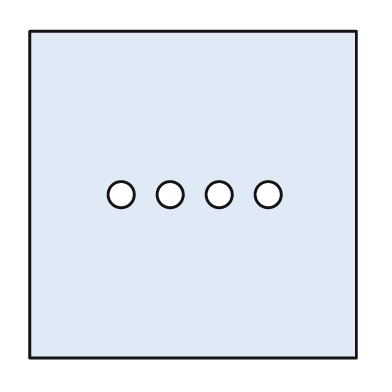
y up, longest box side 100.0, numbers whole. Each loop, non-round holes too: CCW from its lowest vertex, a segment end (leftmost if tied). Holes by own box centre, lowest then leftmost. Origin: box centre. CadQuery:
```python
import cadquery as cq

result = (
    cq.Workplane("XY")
    .moveTo(-50.0, -50.0)
    .lineTo(50.0, -50.0)
    .lineTo(50.0, 50.0)
    .lineTo(-50.0, 50.0)
    .close()
    .moveTo(-22.0, 0.0)
    .circle(4.0)
    .moveTo(-7.0, 0.0)
    .circle(4.0)
    .moveTo(8.0, 0.0)
    .circle(4.0)
    .moveTo(23.0, 0.0)
    .circle(4.0)
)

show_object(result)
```